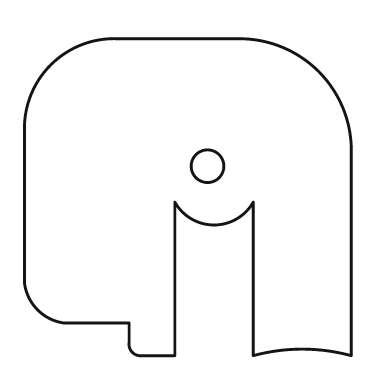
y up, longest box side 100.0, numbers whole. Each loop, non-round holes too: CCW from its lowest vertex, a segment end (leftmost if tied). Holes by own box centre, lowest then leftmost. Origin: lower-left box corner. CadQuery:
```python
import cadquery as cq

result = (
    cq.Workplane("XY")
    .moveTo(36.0, 0.0)
    .lineTo(46.0, 0.0)
    .lineTo(46.0, 47.0)
    .threePointArc((58.0, 40.0), (70.0, 47.0))
    .lineTo(70.0, 0.0)
    .threePointArc((85.0, 2.0), (100.0, 0.0))
    .lineTo(100.0, 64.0)
    .threePointArc((90.0, 87.0), (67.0, 97.0))
    .lineTo(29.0, 97.0)
    .threePointArc((8.0, 89.0), (0.0, 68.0))
    .lineTo(0.0, 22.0)
    .threePointArc((4.0, 14.0), (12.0, 10.0))
    .lineTo(32.0, 10.0)
    .lineTo(32.0, 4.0)
    .threePointArc((33.0, 1.0), (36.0, 0.0))
    .close()
    .moveTo(56.0, 58.0)
    .circle(5.0)
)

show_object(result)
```